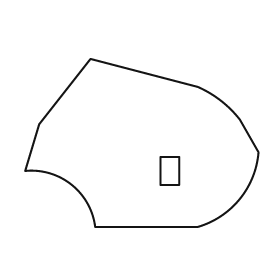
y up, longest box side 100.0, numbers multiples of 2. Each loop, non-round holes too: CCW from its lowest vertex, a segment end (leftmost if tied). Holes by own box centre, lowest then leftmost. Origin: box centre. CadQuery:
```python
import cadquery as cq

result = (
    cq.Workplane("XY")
    .moveTo(-20.0, -36.0)
    .lineTo(24.0, -36.0)
    .threePointArc((42.0, -24.0), (50.0, -4.0))
    .lineTo(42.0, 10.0)
    .threePointArc((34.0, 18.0), (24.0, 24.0))
    .lineTo(-22.0, 36.0)
    .lineTo(-44.0, 8.0)
    .lineTo(-50.0, -12.0)
    .threePointArc((-30.0, -18.0), (-20.0, -36.0))
    .close()
    .moveTo(8.0, -18.0)
    .lineTo(16.0, -18.0)
    .lineTo(16.0, -6.0)
    .lineTo(8.0, -6.0)
    .close()
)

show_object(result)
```